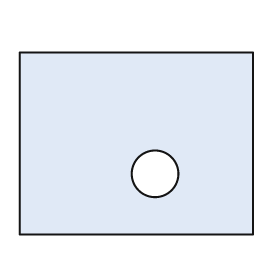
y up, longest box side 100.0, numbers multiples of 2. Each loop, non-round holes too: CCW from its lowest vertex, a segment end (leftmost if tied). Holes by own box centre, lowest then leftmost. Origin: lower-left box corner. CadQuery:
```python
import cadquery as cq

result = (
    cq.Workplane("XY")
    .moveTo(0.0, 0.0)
    .lineTo(100.0, 0.0)
    .lineTo(100.0, 78.0)
    .lineTo(0.0, 78.0)
    .close()
    .moveTo(58.0, 26.0)
    .circle(10.0)
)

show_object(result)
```